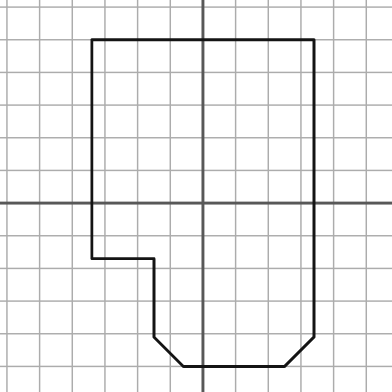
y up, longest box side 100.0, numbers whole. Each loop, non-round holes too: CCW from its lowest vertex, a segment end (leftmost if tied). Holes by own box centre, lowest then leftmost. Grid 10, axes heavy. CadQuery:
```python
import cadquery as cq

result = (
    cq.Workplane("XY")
    .moveTo(-6.0, -50.0)
    .lineTo(25.0, -50.0)
    .lineTo(34.0, -41.0)
    .lineTo(34.0, 50.0)
    .lineTo(-34.0, 50.0)
    .lineTo(-34.0, -17.0)
    .lineTo(-15.0, -17.0)
    .lineTo(-15.0, -41.0)
    .close()
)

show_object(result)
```